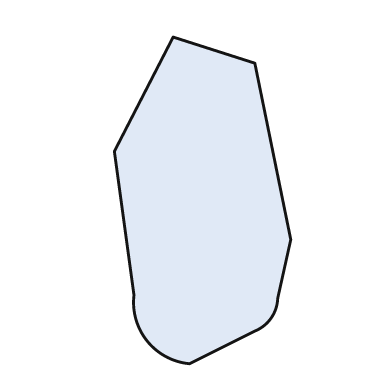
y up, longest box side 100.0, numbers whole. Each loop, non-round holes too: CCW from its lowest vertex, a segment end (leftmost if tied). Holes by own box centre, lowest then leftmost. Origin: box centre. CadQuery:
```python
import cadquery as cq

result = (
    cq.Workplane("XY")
    .moveTo(-4.0, -50.0)
    .lineTo(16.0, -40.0)
    .threePointArc((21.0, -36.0), (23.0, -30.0))
    .lineTo(27.0, -12.0)
    .lineTo(16.0, 42.0)
    .lineTo(-9.0, 50.0)
    .lineTo(-27.0, 15.0)
    .lineTo(-21.0, -29.0)
    .threePointArc((-17.0, -43.0), (-4.0, -50.0))
    .close()
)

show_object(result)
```